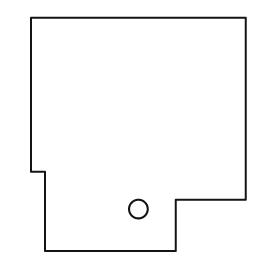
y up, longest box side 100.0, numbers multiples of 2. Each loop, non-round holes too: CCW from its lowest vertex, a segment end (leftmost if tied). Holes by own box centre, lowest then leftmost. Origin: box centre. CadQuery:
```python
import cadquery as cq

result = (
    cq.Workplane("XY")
    .moveTo(-40.0, -50.0)
    .lineTo(16.0, -50.0)
    .lineTo(16.0, -28.0)
    .lineTo(46.0, -28.0)
    .lineTo(46.0, 50.0)
    .lineTo(-46.0, 50.0)
    .lineTo(-46.0, -16.0)
    .lineTo(-40.0, -16.0)
    .close()
    .moveTo(0.0, -32.0)
    .circle(4.0)
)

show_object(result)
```